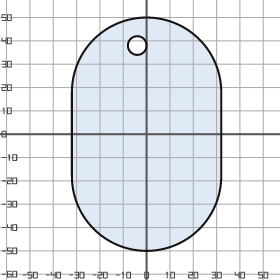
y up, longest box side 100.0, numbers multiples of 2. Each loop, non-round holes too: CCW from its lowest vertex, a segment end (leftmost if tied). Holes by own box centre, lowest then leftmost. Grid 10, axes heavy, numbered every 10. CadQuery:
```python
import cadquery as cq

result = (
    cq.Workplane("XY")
    .moveTo(-32.0, -18.0)
    .threePointArc((0.0, -50.0), (32.0, -18.0))
    .lineTo(32.0, 18.0)
    .threePointArc((0.0, 50.0), (-32.0, 18.0))
    .close()
    .moveTo(-4.0, 38.0)
    .circle(4.0)
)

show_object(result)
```